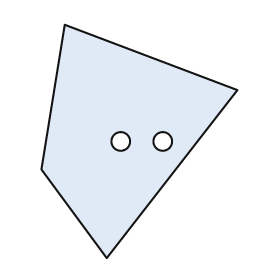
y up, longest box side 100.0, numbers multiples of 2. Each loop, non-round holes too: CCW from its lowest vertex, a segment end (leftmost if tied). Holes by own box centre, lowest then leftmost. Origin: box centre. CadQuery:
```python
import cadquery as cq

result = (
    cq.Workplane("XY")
    .moveTo(-14.0, -50.0)
    .lineTo(42.0, 22.0)
    .lineTo(-32.0, 50.0)
    .lineTo(-42.0, -12.0)
    .close()
    .moveTo(-8.0, 0.0)
    .circle(4.0)
    .moveTo(10.0, 0.0)
    .circle(4.0)
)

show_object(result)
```